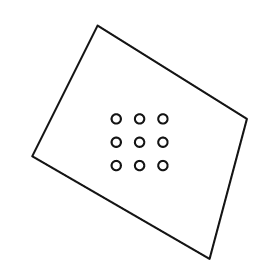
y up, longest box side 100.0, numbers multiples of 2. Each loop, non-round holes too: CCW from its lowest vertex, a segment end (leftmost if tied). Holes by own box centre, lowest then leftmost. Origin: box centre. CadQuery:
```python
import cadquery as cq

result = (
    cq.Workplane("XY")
    .moveTo(30.0, -50.0)
    .lineTo(46.0, 10.0)
    .lineTo(-18.0, 50.0)
    .lineTo(-46.0, -6.0)
    .close()
    .moveTo(-10.0, -10.0)
    .circle(2.0)
    .moveTo(0.0, -10.0)
    .circle(2.0)
    .moveTo(10.0, -10.0)
    .circle(2.0)
    .moveTo(-10.0, 0.0)
    .circle(2.0)
    .moveTo(0.0, 0.0)
    .circle(2.0)
    .moveTo(10.0, 0.0)
    .circle(2.0)
    .moveTo(-10.0, 10.0)
    .circle(2.0)
    .moveTo(0.0, 10.0)
    .circle(2.0)
    .moveTo(10.0, 10.0)
    .circle(2.0)
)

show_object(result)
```